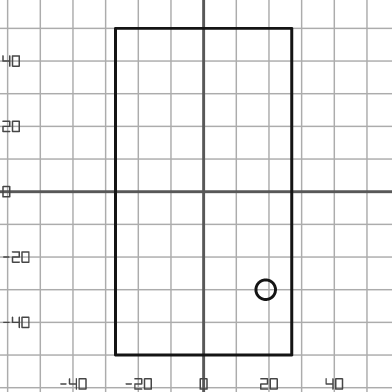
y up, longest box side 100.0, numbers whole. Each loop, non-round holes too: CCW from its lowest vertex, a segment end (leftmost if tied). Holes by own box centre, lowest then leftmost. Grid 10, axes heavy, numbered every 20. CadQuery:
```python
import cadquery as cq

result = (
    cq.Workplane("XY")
    .moveTo(-27.0, -50.0)
    .lineTo(27.0, -50.0)
    .lineTo(27.0, 50.0)
    .lineTo(-27.0, 50.0)
    .close()
    .moveTo(19.0, -30.0)
    .circle(3.0)
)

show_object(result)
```